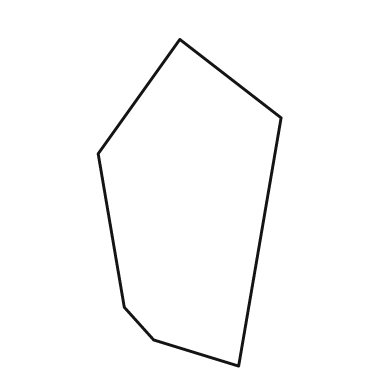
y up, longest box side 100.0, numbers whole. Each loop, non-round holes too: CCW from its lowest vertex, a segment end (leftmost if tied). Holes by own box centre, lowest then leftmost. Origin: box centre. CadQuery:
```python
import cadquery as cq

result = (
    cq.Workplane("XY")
    .moveTo(15.0, -50.0)
    .lineTo(28.0, 26.0)
    .lineTo(-3.0, 50.0)
    .lineTo(-28.0, 15.0)
    .lineTo(-20.0, -32.0)
    .lineTo(-11.0, -42.0)
    .close()
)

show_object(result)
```